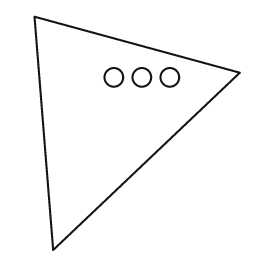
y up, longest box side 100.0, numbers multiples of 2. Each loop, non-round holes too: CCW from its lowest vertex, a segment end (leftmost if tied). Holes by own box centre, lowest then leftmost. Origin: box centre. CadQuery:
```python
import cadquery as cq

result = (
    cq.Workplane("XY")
    .moveTo(-36.0, -50.0)
    .lineTo(44.0, 26.0)
    .lineTo(-44.0, 50.0)
    .close()
    .moveTo(-10.0, 24.0)
    .circle(4.0)
    .moveTo(2.0, 24.0)
    .circle(4.0)
    .moveTo(14.0, 24.0)
    .circle(4.0)
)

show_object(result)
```